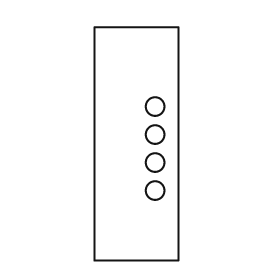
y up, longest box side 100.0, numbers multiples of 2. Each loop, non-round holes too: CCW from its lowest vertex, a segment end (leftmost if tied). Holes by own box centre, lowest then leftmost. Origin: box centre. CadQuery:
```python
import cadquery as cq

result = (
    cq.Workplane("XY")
    .moveTo(-18.0, -50.0)
    .lineTo(18.0, -50.0)
    .lineTo(18.0, 50.0)
    .lineTo(-18.0, 50.0)
    .close()
    .moveTo(8.0, -20.0)
    .circle(4.0)
    .moveTo(8.0, -8.0)
    .circle(4.0)
    .moveTo(8.0, 4.0)
    .circle(4.0)
    .moveTo(8.0, 16.0)
    .circle(4.0)
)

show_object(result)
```